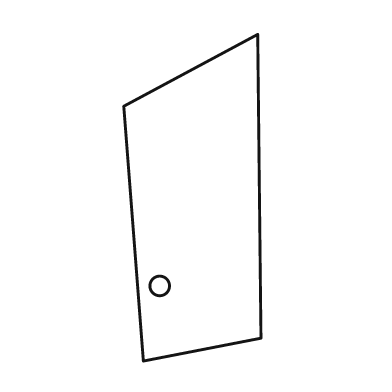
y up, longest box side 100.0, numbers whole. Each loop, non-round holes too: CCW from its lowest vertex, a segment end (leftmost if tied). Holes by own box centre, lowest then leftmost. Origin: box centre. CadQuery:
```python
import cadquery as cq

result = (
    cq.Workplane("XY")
    .moveTo(-15.0, -50.0)
    .lineTo(21.0, -43.0)
    .lineTo(20.0, 50.0)
    .lineTo(-21.0, 28.0)
    .close()
    .moveTo(-10.0, -27.0)
    .circle(3.0)
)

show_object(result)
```